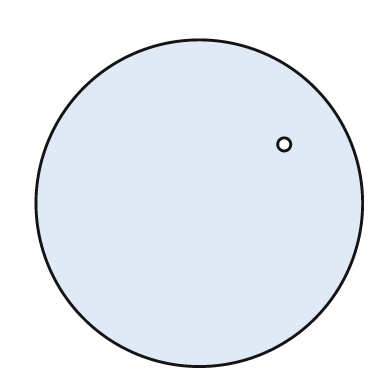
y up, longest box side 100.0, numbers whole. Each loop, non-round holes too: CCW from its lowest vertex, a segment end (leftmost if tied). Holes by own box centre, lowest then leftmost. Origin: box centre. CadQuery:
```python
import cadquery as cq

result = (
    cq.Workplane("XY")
    .moveTo(0.0, 0.0)
    .circle(50.0)
    .moveTo(26.0, 18.0)
    .circle(2.0)
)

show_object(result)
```